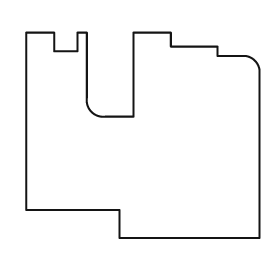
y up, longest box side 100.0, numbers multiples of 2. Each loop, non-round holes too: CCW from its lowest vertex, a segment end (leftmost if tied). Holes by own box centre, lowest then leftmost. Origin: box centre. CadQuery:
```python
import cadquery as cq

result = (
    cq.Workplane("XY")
    .moveTo(-10.0, -44.0)
    .lineTo(50.0, -44.0)
    .lineTo(50.0, 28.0)
    .threePointArc((48.0, 32.0), (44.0, 34.0))
    .lineTo(32.0, 34.0)
    .lineTo(32.0, 38.0)
    .lineTo(12.0, 38.0)
    .lineTo(12.0, 44.0)
    .lineTo(-4.0, 44.0)
    .lineTo(-4.0, 8.0)
    .lineTo(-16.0, 8.0)
    .threePointArc((-22.0, 10.0), (-24.0, 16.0))
    .lineTo(-24.0, 44.0)
    .lineTo(-28.0, 44.0)
    .lineTo(-28.0, 36.0)
    .lineTo(-38.0, 36.0)
    .lineTo(-38.0, 44.0)
    .lineTo(-50.0, 44.0)
    .lineTo(-50.0, -32.0)
    .lineTo(-10.0, -32.0)
    .close()
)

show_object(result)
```